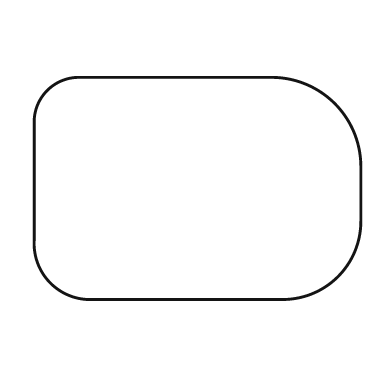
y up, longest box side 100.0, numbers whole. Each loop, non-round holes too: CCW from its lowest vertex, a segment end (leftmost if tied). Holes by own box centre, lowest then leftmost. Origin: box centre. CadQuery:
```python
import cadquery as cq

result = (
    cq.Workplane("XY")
    .moveTo(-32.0, -34.0)
    .lineTo(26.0, -34.0)
    .threePointArc((43.0, -27.0), (50.0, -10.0))
    .lineTo(50.0, 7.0)
    .threePointArc((42.0, 26.0), (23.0, 34.0))
    .lineTo(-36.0, 34.0)
    .threePointArc((-46.0, 30.0), (-50.0, 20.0))
    .lineTo(-50.0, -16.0)
    .threePointArc((-45.0, -29.0), (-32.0, -34.0))
    .close()
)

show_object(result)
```